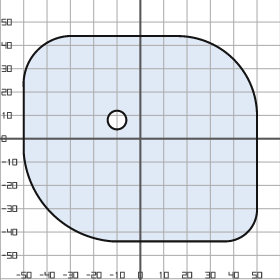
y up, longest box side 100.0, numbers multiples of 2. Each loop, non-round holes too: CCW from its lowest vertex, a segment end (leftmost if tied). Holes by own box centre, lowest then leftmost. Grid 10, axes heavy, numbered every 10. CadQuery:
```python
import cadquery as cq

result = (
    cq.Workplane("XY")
    .moveTo(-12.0, -44.0)
    .lineTo(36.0, -44.0)
    .threePointArc((46.0, -40.0), (50.0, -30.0))
    .lineTo(50.0, 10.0)
    .threePointArc((40.0, 34.0), (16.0, 44.0))
    .lineTo(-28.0, 44.0)
    .threePointArc((-44.0, 38.0), (-50.0, 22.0))
    .lineTo(-50.0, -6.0)
    .threePointArc((-38.0, -32.0), (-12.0, -44.0))
    .close()
    .moveTo(-10.0, 8.0)
    .circle(4.0)
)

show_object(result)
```